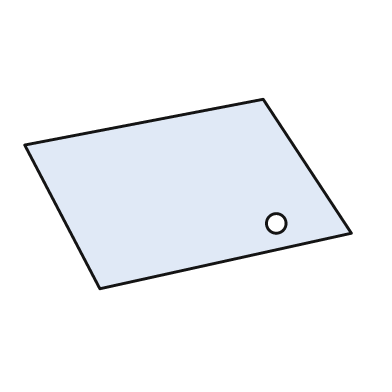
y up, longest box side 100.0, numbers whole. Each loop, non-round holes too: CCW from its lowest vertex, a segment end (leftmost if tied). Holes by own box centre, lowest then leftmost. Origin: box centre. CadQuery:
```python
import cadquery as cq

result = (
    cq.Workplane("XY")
    .moveTo(-27.0, -29.0)
    .lineTo(50.0, -12.0)
    .lineTo(23.0, 29.0)
    .lineTo(-50.0, 15.0)
    .close()
    .moveTo(27.0, -9.0)
    .circle(3.0)
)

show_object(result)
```